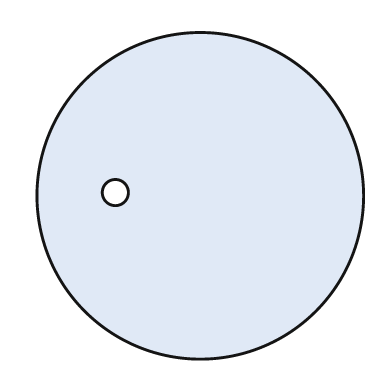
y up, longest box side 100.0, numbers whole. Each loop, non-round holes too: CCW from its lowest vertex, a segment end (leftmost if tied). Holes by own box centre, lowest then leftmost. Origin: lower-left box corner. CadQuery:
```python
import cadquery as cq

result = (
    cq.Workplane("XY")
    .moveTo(50.0, 50.0)
    .circle(50.0)
    .moveTo(24.0, 51.0)
    .circle(4.0)
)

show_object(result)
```